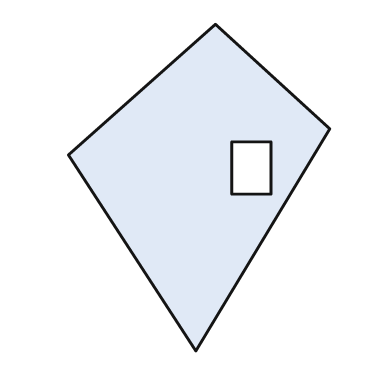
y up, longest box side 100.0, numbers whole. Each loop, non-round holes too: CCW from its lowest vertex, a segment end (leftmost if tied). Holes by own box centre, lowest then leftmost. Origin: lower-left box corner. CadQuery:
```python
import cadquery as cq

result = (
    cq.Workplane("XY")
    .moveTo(39.0, 0.0)
    .lineTo(80.0, 68.0)
    .lineTo(45.0, 100.0)
    .lineTo(0.0, 60.0)
    .close()
    .moveTo(50.0, 48.0)
    .lineTo(62.0, 48.0)
    .lineTo(62.0, 64.0)
    .lineTo(50.0, 64.0)
    .close()
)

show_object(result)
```